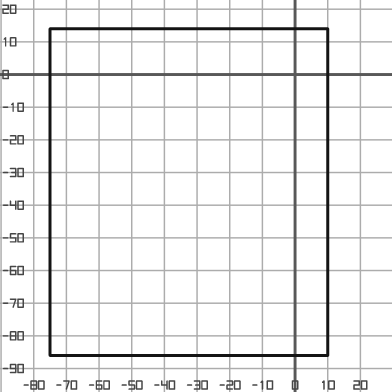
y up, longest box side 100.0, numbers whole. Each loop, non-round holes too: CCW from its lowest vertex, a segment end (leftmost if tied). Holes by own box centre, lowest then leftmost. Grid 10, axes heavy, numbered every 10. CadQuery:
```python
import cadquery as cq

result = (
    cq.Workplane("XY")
    .moveTo(-75.0, -86.0)
    .lineTo(10.0, -86.0)
    .lineTo(10.0, 14.0)
    .lineTo(-75.0, 14.0)
    .close()
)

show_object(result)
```